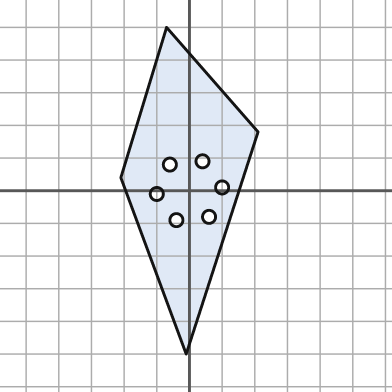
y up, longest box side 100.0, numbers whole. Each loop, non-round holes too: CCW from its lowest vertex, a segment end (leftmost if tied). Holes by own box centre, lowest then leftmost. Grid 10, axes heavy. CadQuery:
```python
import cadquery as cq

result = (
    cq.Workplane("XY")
    .moveTo(-1.0, -50.0)
    .lineTo(21.0, 18.0)
    .lineTo(-7.0, 50.0)
    .lineTo(-21.0, 4.0)
    .close()
    .moveTo(-4.0, -9.0)
    .circle(2.0)
    .moveTo(6.0, -8.0)
    .circle(2.0)
    .moveTo(-10.0, -1.0)
    .circle(2.0)
    .moveTo(10.0, 1.0)
    .circle(2.0)
    .moveTo(-6.0, 8.0)
    .circle(2.0)
    .moveTo(4.0, 9.0)
    .circle(2.0)
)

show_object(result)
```